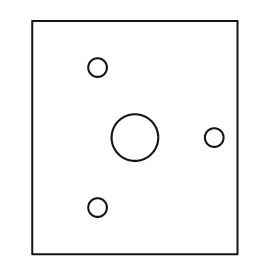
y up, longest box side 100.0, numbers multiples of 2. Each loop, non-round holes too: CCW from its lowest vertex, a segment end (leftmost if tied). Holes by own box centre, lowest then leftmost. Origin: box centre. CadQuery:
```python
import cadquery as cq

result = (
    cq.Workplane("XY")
    .moveTo(-44.0, -50.0)
    .lineTo(44.0, -50.0)
    .lineTo(44.0, 50.0)
    .lineTo(-44.0, 50.0)
    .close()
    .moveTo(-16.0, -30.0)
    .circle(4.0)
    .moveTo(0.0, 0.0)
    .circle(10.0)
    .moveTo(34.0, 0.0)
    .circle(4.0)
    .moveTo(-16.0, 30.0)
    .circle(4.0)
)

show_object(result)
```